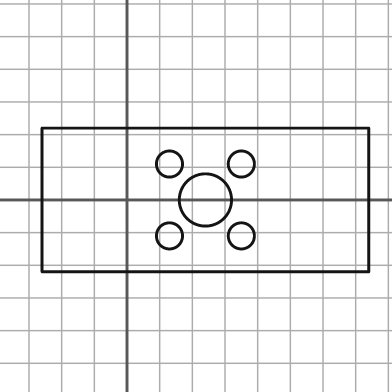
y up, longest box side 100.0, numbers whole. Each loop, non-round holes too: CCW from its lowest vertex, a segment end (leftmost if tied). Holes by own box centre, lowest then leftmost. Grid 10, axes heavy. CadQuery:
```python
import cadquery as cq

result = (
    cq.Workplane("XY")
    .moveTo(-26.0, -22.0)
    .lineTo(74.0, -22.0)
    .lineTo(74.0, 22.0)
    .lineTo(-26.0, 22.0)
    .close()
    .moveTo(13.0, -11.0)
    .circle(4.0)
    .moveTo(35.0, -11.0)
    .circle(4.0)
    .moveTo(24.0, 0.0)
    .circle(8.0)
    .moveTo(13.0, 11.0)
    .circle(4.0)
    .moveTo(35.0, 11.0)
    .circle(4.0)
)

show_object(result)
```